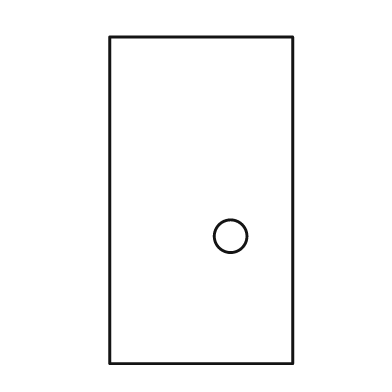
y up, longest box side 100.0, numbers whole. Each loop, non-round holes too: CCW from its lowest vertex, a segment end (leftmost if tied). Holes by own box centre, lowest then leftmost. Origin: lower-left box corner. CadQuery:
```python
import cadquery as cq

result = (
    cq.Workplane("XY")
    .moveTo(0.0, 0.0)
    .lineTo(56.0, 0.0)
    .lineTo(56.0, 100.0)
    .lineTo(0.0, 100.0)
    .close()
    .moveTo(37.0, 39.0)
    .circle(5.0)
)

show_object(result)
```